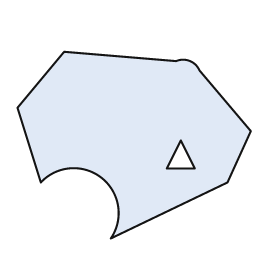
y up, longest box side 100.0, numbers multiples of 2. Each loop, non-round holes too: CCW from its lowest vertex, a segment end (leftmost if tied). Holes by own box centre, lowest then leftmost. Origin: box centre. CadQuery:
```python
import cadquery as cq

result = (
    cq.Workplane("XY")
    .moveTo(-10.0, -40.0)
    .lineTo(40.0, -16.0)
    .lineTo(50.0, 6.0)
    .lineTo(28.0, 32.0)
    .threePointArc((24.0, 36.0), (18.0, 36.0))
    .lineTo(-30.0, 40.0)
    .lineTo(-50.0, 16.0)
    .lineTo(-40.0, -16.0)
    .threePointArc((-14.0, -14.0), (-10.0, -40.0))
    .close()
    .moveTo(14.0, -10.0)
    .lineTo(26.0, -10.0)
    .lineTo(20.0, 2.0)
    .close()
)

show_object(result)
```